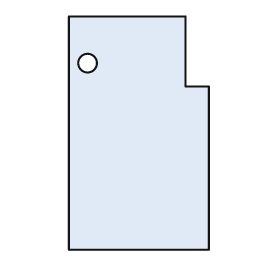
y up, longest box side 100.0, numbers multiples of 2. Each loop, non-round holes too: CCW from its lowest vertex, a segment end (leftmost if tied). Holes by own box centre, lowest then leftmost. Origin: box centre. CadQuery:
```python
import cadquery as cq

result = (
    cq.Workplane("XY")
    .moveTo(-30.0, -50.0)
    .lineTo(30.0, -50.0)
    .lineTo(30.0, 20.0)
    .lineTo(20.0, 20.0)
    .lineTo(20.0, 50.0)
    .lineTo(-30.0, 50.0)
    .close()
    .moveTo(-22.0, 30.0)
    .circle(4.0)
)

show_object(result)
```